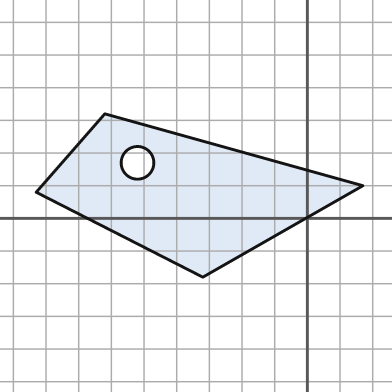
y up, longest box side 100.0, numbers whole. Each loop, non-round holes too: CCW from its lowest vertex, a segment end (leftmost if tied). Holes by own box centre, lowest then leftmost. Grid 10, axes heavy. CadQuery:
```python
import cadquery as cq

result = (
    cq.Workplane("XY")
    .moveTo(-32.0, -18.0)
    .lineTo(17.0, 10.0)
    .lineTo(-62.0, 32.0)
    .lineTo(-83.0, 8.0)
    .close()
    .moveTo(-52.0, 17.0)
    .circle(5.0)
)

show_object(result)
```